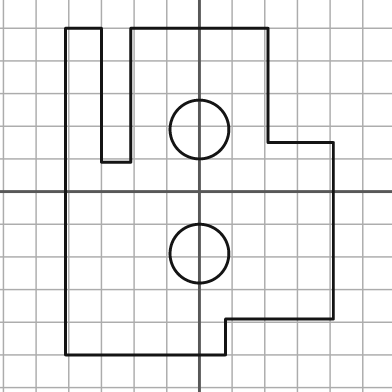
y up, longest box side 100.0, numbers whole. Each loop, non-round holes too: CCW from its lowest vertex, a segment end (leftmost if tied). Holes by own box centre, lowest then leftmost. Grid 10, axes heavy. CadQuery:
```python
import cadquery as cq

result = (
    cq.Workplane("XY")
    .moveTo(-41.0, -50.0)
    .lineTo(8.0, -50.0)
    .lineTo(8.0, -39.0)
    .lineTo(41.0, -39.0)
    .lineTo(41.0, 15.0)
    .lineTo(21.0, 15.0)
    .lineTo(21.0, 50.0)
    .lineTo(-21.0, 50.0)
    .lineTo(-21.0, 9.0)
    .lineTo(-30.0, 9.0)
    .lineTo(-30.0, 50.0)
    .lineTo(-41.0, 50.0)
    .close()
    .moveTo(0.0, -19.0)
    .circle(9.0)
    .moveTo(0.0, 19.0)
    .circle(9.0)
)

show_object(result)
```